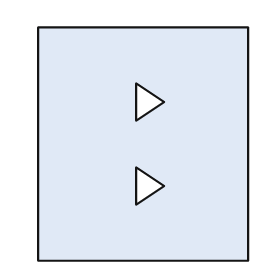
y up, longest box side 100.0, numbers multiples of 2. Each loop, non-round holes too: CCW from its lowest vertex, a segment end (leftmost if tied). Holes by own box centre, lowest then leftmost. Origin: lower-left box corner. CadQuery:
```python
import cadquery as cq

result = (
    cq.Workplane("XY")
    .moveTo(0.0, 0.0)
    .lineTo(90.0, 0.0)
    .lineTo(90.0, 100.0)
    .lineTo(0.0, 100.0)
    .close()
    .moveTo(42.0, 24.0)
    .lineTo(54.0, 32.0)
    .lineTo(42.0, 40.0)
    .close()
    .moveTo(42.0, 60.0)
    .lineTo(54.0, 68.0)
    .lineTo(42.0, 76.0)
    .close()
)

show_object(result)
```